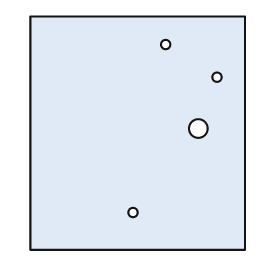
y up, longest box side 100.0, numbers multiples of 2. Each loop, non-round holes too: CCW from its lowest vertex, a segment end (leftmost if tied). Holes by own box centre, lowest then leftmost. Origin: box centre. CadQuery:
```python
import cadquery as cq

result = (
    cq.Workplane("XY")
    .moveTo(-46.0, -50.0)
    .lineTo(46.0, -50.0)
    .lineTo(46.0, 50.0)
    .lineTo(-46.0, 50.0)
    .close()
    .moveTo(-2.0, -34.0)
    .circle(2.0)
    .moveTo(26.0, 2.0)
    .circle(4.0)
    .moveTo(34.0, 24.0)
    .circle(2.0)
    .moveTo(12.0, 38.0)
    .circle(2.0)
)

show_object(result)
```